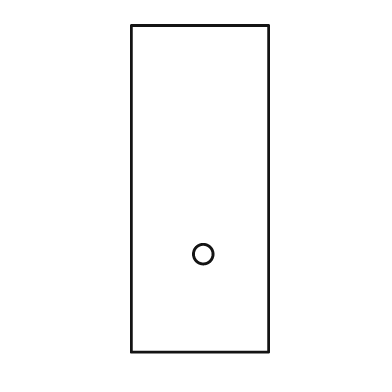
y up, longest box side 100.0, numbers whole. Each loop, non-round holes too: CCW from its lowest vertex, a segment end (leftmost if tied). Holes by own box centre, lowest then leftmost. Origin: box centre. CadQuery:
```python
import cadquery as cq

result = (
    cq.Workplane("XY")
    .moveTo(-21.0, -50.0)
    .lineTo(21.0, -50.0)
    .lineTo(21.0, 50.0)
    .lineTo(-21.0, 50.0)
    .close()
    .moveTo(1.0, -20.0)
    .circle(3.0)
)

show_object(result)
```